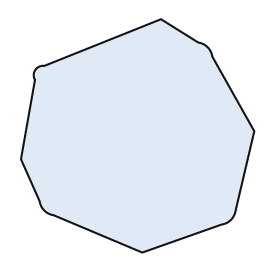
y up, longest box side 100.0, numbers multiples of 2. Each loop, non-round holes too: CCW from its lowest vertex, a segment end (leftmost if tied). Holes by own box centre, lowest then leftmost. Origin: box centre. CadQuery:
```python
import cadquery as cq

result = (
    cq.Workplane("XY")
    .moveTo(2.0, -50.0)
    .lineTo(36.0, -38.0)
    .threePointArc((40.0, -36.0), (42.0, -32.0))
    .lineTo(50.0, 2.0)
    .lineTo(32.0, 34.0)
    .threePointArc((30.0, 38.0), (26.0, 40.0))
    .lineTo(10.0, 50.0)
    .lineTo(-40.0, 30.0)
    .threePointArc((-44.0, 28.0), (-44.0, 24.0))
    .lineTo(-50.0, -10.0)
    .lineTo(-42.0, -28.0)
    .threePointArc((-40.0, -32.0), (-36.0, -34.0))
    .close()
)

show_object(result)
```